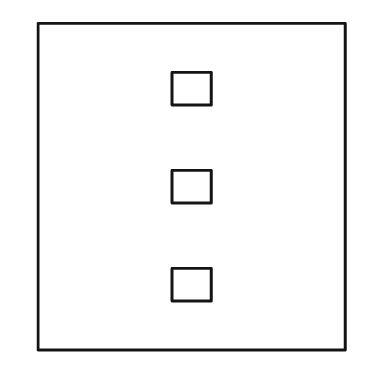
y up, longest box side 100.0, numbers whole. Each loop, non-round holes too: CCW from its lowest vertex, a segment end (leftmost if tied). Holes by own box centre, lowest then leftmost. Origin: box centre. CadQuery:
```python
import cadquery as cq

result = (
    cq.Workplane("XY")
    .moveTo(-47.0, -50.0)
    .lineTo(47.0, -50.0)
    .lineTo(47.0, 50.0)
    .lineTo(-47.0, 50.0)
    .close()
    .moveTo(-6.0, -35.0)
    .lineTo(6.0, -35.0)
    .lineTo(6.0, -25.0)
    .lineTo(-6.0, -25.0)
    .close()
    .moveTo(-6.0, -5.0)
    .lineTo(6.0, -5.0)
    .lineTo(6.0, 5.0)
    .lineTo(-6.0, 5.0)
    .close()
    .moveTo(-6.0, 25.0)
    .lineTo(6.0, 25.0)
    .lineTo(6.0, 35.0)
    .lineTo(-6.0, 35.0)
    .close()
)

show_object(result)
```